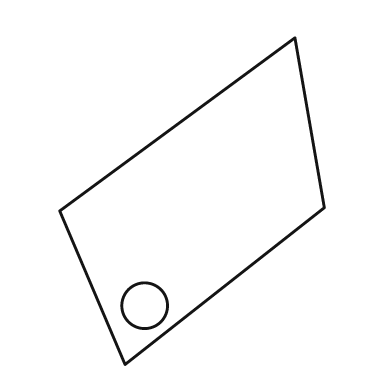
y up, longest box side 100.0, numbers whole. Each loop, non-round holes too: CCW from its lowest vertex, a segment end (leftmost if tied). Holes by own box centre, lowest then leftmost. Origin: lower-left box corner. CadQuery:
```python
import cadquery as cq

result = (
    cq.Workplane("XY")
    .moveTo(20.0, 0.0)
    .lineTo(81.0, 48.0)
    .lineTo(72.0, 100.0)
    .lineTo(0.0, 47.0)
    .close()
    .moveTo(26.0, 18.0)
    .circle(7.0)
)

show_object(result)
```